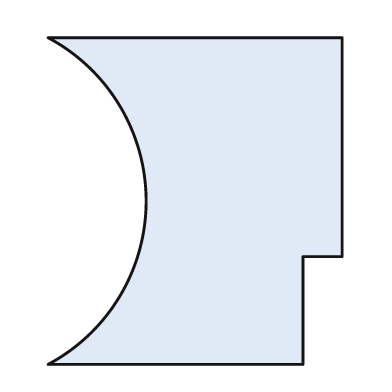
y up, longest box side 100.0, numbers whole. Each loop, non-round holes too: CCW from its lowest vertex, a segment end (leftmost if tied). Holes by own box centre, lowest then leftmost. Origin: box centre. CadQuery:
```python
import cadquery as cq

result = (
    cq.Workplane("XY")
    .moveTo(-45.0, -50.0)
    .lineTo(33.0, -50.0)
    .lineTo(33.0, -17.0)
    .lineTo(45.0, -17.0)
    .lineTo(45.0, 50.0)
    .lineTo(-45.0, 50.0)
    .threePointArc((-15.0, 0.0), (-45.0, -50.0))
    .close()
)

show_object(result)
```